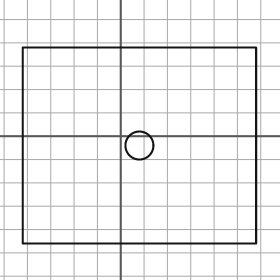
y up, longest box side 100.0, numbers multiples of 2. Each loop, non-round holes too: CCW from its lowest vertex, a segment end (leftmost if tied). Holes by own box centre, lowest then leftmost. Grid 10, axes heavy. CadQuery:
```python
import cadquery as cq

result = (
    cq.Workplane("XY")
    .moveTo(-42.0, -46.0)
    .lineTo(58.0, -46.0)
    .lineTo(58.0, 38.0)
    .lineTo(-42.0, 38.0)
    .close()
    .moveTo(8.0, -4.0)
    .circle(6.0)
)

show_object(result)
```